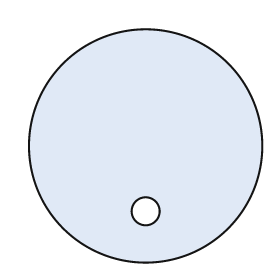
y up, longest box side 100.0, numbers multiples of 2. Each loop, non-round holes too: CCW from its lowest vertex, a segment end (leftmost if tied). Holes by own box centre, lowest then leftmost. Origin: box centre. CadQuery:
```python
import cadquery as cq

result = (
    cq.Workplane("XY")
    .moveTo(0.0, 0.0)
    .circle(50.0)
    .moveTo(0.0, -28.0)
    .circle(6.0)
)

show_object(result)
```